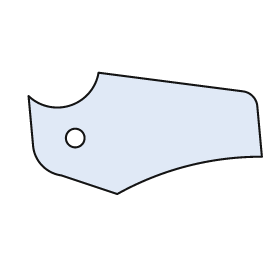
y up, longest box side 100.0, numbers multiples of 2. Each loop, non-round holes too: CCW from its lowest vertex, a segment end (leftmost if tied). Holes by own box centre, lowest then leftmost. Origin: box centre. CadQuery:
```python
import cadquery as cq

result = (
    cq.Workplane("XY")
    .moveTo(-12.0, -26.0)
    .threePointArc((18.0, -14.0), (50.0, -10.0))
    .lineTo(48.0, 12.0)
    .threePointArc((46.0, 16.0), (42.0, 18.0))
    .lineTo(-20.0, 26.0)
    .threePointArc((-32.0, 12.0), (-50.0, 16.0))
    .lineTo(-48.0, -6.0)
    .threePointArc((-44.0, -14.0), (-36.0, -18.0))
    .close()
    .moveTo(-30.0, -2.0)
    .circle(4.0)
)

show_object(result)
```